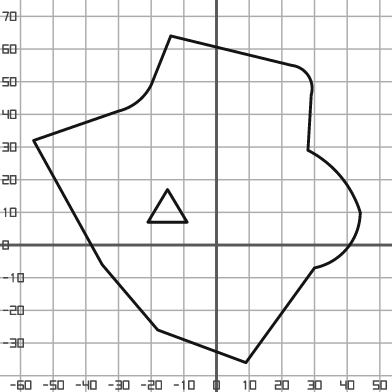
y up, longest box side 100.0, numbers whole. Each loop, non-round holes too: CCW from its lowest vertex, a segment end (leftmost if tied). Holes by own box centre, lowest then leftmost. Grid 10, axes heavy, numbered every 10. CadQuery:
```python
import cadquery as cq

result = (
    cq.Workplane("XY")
    .moveTo(9.0, -36.0)
    .lineTo(30.0, -7.0)
    .threePointArc((40.0, -1.0), (44.0, 10.0))
    .threePointArc((38.0, 21.0), (28.0, 29.0))
    .lineTo(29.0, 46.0)
    .threePointArc((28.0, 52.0), (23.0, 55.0))
    .lineTo(-14.0, 64.0)
    .lineTo(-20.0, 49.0)
    .threePointArc((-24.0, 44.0), (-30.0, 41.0))
    .lineTo(-56.0, 32.0)
    .lineTo(-35.0, -6.0)
    .lineTo(-18.0, -26.0)
    .close()
    .moveTo(-21.0, 7.0)
    .lineTo(-9.0, 7.0)
    .lineTo(-15.0, 17.0)
    .close()
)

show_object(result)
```